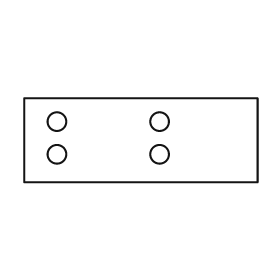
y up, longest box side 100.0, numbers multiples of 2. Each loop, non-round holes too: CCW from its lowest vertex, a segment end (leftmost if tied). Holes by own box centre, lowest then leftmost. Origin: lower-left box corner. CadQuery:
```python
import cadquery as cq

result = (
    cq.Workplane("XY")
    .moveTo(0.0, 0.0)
    .lineTo(100.0, 0.0)
    .lineTo(100.0, 36.0)
    .lineTo(0.0, 36.0)
    .close()
    .moveTo(14.0, 12.0)
    .circle(4.0)
    .moveTo(58.0, 12.0)
    .circle(4.0)
    .moveTo(14.0, 26.0)
    .circle(4.0)
    .moveTo(58.0, 26.0)
    .circle(4.0)
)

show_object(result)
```